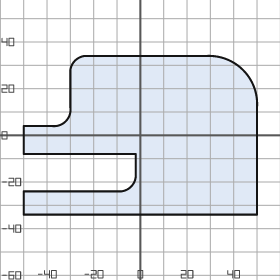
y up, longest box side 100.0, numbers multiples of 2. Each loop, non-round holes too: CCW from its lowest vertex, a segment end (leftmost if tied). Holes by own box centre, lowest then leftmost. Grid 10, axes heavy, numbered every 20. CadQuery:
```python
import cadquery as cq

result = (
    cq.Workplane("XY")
    .moveTo(-50.0, -34.0)
    .lineTo(50.0, -34.0)
    .lineTo(50.0, 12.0)
    .threePointArc((44.0, 28.0), (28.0, 34.0))
    .lineTo(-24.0, 34.0)
    .threePointArc((-28.0, 32.0), (-30.0, 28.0))
    .lineTo(-30.0, 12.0)
    .threePointArc((-32.0, 6.0), (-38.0, 4.0))
    .lineTo(-50.0, 4.0)
    .lineTo(-50.0, -8.0)
    .lineTo(-2.0, -8.0)
    .lineTo(-2.0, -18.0)
    .threePointArc((-4.0, -22.0), (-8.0, -24.0))
    .lineTo(-50.0, -24.0)
    .close()
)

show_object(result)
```